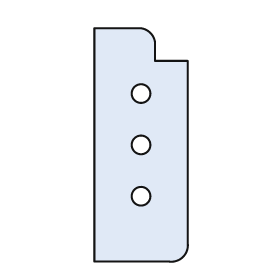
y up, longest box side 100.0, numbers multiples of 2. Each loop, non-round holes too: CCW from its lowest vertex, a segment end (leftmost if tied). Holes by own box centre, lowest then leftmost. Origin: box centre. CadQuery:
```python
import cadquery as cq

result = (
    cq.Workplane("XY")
    .moveTo(-20.0, -50.0)
    .lineTo(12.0, -50.0)
    .threePointArc((18.0, -48.0), (20.0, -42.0))
    .lineTo(20.0, 36.0)
    .lineTo(6.0, 36.0)
    .lineTo(6.0, 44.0)
    .threePointArc((4.0, 48.0), (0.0, 50.0))
    .lineTo(-20.0, 50.0)
    .close()
    .moveTo(0.0, -22.0)
    .circle(4.0)
    .moveTo(0.0, 0.0)
    .circle(4.0)
    .moveTo(0.0, 22.0)
    .circle(4.0)
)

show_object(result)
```